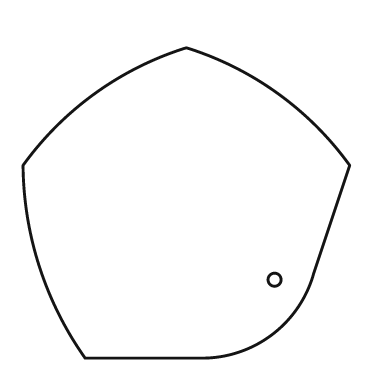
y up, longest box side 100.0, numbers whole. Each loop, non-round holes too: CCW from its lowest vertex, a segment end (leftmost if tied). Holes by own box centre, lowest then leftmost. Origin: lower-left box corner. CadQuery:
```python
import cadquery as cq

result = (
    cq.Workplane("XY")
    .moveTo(19.0, 0.0)
    .lineTo(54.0, 0.0)
    .threePointArc((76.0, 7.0), (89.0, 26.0))
    .lineTo(100.0, 59.0)
    .threePointArc((78.0, 81.0), (50.0, 95.0))
    .threePointArc((22.0, 81.0), (0.0, 59.0))
    .threePointArc((5.0, 28.0), (19.0, 0.0))
    .close()
    .moveTo(77.0, 24.0)
    .circle(2.0)
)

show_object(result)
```